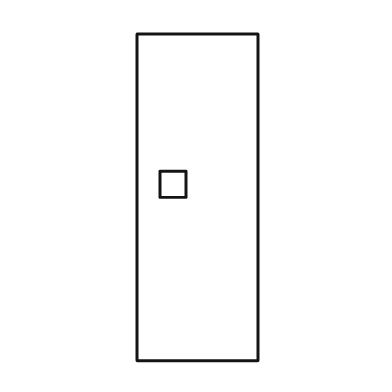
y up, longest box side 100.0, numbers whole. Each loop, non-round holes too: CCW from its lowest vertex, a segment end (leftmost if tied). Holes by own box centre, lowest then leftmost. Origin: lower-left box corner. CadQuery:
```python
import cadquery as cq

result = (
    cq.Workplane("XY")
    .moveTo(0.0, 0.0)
    .lineTo(37.0, 0.0)
    .lineTo(37.0, 100.0)
    .lineTo(0.0, 100.0)
    .close()
    .moveTo(7.0, 50.0)
    .lineTo(15.0, 50.0)
    .lineTo(15.0, 58.0)
    .lineTo(7.0, 58.0)
    .close()
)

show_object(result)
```